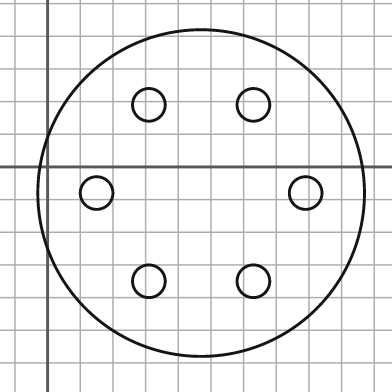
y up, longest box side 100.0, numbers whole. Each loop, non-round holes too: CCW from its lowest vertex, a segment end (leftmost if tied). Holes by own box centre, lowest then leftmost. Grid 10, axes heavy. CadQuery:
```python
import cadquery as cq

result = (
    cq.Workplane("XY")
    .moveTo(47.0, -8.0)
    .circle(50.0)
    .moveTo(31.0, -35.0)
    .circle(5.0)
    .moveTo(63.0, -35.0)
    .circle(5.0)
    .moveTo(15.0, -8.0)
    .circle(5.0)
    .moveTo(79.0, -8.0)
    .circle(5.0)
    .moveTo(31.0, 19.0)
    .circle(5.0)
    .moveTo(63.0, 19.0)
    .circle(5.0)
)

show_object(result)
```